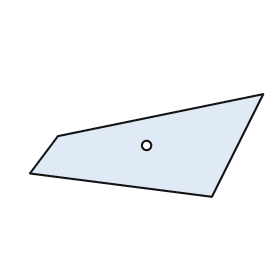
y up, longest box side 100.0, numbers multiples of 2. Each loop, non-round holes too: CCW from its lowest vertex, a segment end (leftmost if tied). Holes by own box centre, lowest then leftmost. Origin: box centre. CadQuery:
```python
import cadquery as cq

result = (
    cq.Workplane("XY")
    .moveTo(28.0, -22.0)
    .lineTo(50.0, 22.0)
    .lineTo(-38.0, 4.0)
    .lineTo(-50.0, -12.0)
    .close()
    .moveTo(0.0, 0.0)
    .circle(2.0)
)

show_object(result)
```